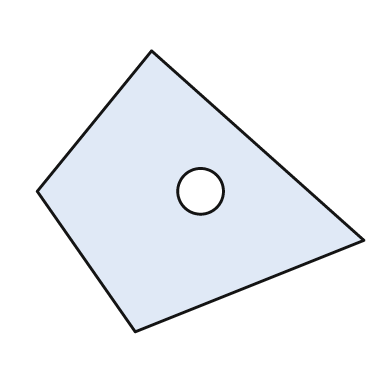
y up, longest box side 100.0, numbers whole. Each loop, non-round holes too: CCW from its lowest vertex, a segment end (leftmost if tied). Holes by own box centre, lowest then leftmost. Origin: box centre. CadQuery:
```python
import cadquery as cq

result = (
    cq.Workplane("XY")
    .moveTo(-20.0, -43.0)
    .lineTo(50.0, -15.0)
    .lineTo(-15.0, 43.0)
    .lineTo(-50.0, 0.0)
    .close()
    .moveTo(0.0, 0.0)
    .circle(7.0)
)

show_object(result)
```